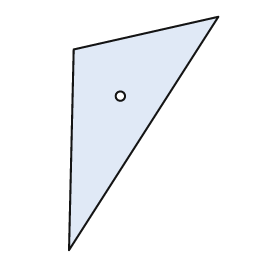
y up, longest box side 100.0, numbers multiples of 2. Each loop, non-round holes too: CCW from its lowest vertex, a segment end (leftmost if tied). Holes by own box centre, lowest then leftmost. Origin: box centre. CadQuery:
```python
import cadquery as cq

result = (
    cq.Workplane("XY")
    .moveTo(-32.0, -50.0)
    .lineTo(32.0, 50.0)
    .lineTo(-30.0, 36.0)
    .close()
    .moveTo(-10.0, 16.0)
    .circle(2.0)
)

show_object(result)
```